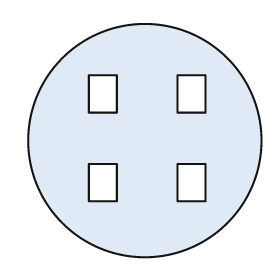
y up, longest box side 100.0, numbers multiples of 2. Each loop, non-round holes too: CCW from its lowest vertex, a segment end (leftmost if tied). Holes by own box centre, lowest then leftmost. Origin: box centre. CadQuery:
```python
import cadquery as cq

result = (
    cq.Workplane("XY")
    .moveTo(0.0, 0.0)
    .circle(50.0)
    .moveTo(-24.0, -26.0)
    .lineTo(-12.0, -26.0)
    .lineTo(-12.0, -10.0)
    .lineTo(-24.0, -10.0)
    .close()
    .moveTo(14.0, -26.0)
    .lineTo(26.0, -26.0)
    .lineTo(26.0, -10.0)
    .lineTo(14.0, -10.0)
    .close()
    .moveTo(-24.0, 12.0)
    .lineTo(-12.0, 12.0)
    .lineTo(-12.0, 28.0)
    .lineTo(-24.0, 28.0)
    .close()
    .moveTo(14.0, 12.0)
    .lineTo(26.0, 12.0)
    .lineTo(26.0, 28.0)
    .lineTo(14.0, 28.0)
    .close()
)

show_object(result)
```